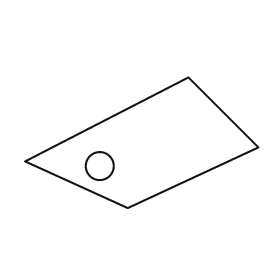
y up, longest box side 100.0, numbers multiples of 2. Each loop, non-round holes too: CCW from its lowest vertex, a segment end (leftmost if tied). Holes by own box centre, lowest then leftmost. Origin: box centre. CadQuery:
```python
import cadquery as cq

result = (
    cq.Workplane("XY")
    .moveTo(-6.0, -28.0)
    .lineTo(50.0, -2.0)
    .lineTo(20.0, 28.0)
    .lineTo(-50.0, -8.0)
    .close()
    .moveTo(-18.0, -10.0)
    .circle(6.0)
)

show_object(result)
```